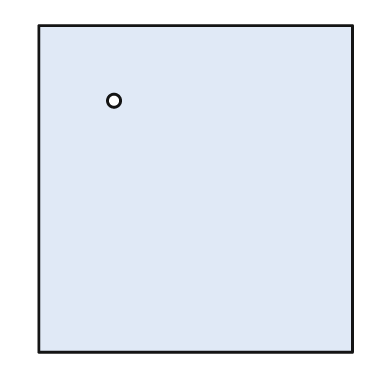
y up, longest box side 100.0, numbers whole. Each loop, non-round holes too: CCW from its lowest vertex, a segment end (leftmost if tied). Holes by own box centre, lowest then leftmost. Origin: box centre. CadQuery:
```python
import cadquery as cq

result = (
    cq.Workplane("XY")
    .moveTo(-48.0, -50.0)
    .lineTo(48.0, -50.0)
    .lineTo(48.0, 50.0)
    .lineTo(-48.0, 50.0)
    .close()
    .moveTo(-25.0, 27.0)
    .circle(2.0)
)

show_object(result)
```